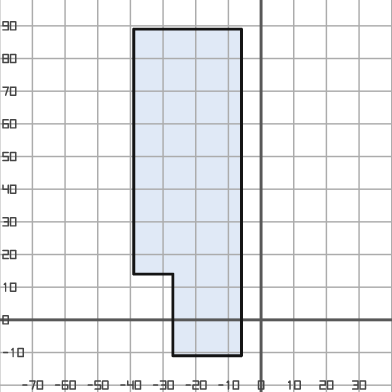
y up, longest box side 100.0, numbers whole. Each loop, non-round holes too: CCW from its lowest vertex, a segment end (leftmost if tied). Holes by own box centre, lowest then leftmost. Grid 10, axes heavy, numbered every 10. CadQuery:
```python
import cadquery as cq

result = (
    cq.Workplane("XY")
    .moveTo(-27.0, -11.0)
    .lineTo(-6.0, -11.0)
    .lineTo(-6.0, 89.0)
    .lineTo(-39.0, 89.0)
    .lineTo(-39.0, 14.0)
    .lineTo(-27.0, 14.0)
    .close()
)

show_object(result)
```